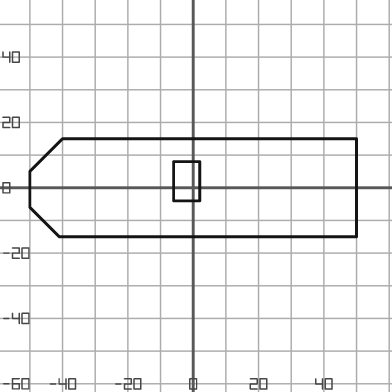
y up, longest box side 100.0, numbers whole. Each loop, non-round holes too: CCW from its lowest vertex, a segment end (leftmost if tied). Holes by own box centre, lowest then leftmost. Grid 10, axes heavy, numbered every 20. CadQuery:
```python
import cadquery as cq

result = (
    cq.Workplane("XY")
    .moveTo(-41.0, -15.0)
    .lineTo(50.0, -15.0)
    .lineTo(50.0, 15.0)
    .lineTo(-40.0, 15.0)
    .lineTo(-50.0, 5.0)
    .lineTo(-50.0, -6.0)
    .close()
    .moveTo(-6.0, -4.0)
    .lineTo(2.0, -4.0)
    .lineTo(2.0, 8.0)
    .lineTo(-6.0, 8.0)
    .close()
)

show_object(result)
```